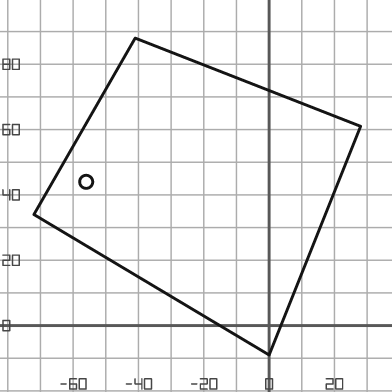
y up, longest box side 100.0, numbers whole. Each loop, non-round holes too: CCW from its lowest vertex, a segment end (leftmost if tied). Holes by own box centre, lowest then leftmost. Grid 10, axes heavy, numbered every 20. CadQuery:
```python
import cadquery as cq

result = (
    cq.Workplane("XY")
    .moveTo(0.0, -9.0)
    .lineTo(28.0, 61.0)
    .lineTo(-41.0, 88.0)
    .lineTo(-72.0, 34.0)
    .close()
    .moveTo(-56.0, 44.0)
    .circle(2.0)
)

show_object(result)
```